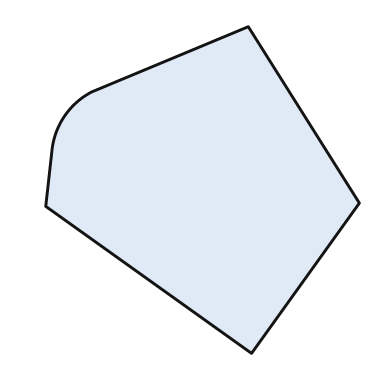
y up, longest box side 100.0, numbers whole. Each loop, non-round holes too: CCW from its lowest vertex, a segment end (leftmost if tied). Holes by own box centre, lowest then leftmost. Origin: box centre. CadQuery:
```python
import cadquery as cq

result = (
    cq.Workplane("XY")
    .moveTo(15.0, -50.0)
    .lineTo(48.0, -4.0)
    .lineTo(14.0, 50.0)
    .lineTo(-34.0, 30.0)
    .threePointArc((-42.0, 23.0), (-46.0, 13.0))
    .lineTo(-48.0, -5.0)
    .close()
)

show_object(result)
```